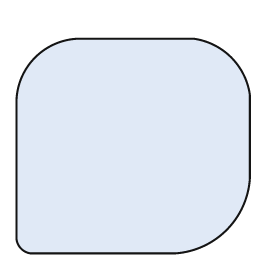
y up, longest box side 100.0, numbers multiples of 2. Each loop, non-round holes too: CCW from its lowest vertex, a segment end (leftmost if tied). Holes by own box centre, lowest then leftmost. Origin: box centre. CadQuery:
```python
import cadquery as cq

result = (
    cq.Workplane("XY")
    .moveTo(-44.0, -46.0)
    .lineTo(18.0, -46.0)
    .threePointArc((40.0, -36.0), (50.0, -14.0))
    .lineTo(50.0, 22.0)
    .threePointArc((42.0, 38.0), (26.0, 46.0))
    .lineTo(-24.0, 46.0)
    .threePointArc((-42.0, 38.0), (-50.0, 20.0))
    .lineTo(-50.0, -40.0)
    .threePointArc((-48.0, -44.0), (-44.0, -46.0))
    .close()
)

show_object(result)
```